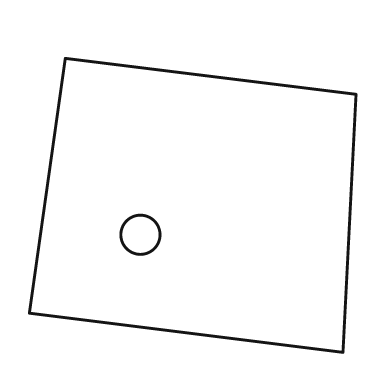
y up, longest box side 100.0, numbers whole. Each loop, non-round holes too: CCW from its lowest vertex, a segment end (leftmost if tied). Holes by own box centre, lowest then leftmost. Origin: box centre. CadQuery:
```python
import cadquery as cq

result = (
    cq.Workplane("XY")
    .moveTo(46.0, -45.0)
    .lineTo(50.0, 34.0)
    .lineTo(-39.0, 45.0)
    .lineTo(-50.0, -33.0)
    .close()
    .moveTo(-16.0, -9.0)
    .circle(6.0)
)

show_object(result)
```